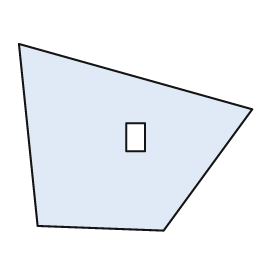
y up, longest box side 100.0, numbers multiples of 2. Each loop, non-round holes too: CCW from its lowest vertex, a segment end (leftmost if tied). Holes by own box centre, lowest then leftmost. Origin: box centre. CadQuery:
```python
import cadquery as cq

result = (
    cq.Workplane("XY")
    .moveTo(12.0, -40.0)
    .lineTo(50.0, 12.0)
    .lineTo(-50.0, 40.0)
    .lineTo(-42.0, -38.0)
    .close()
    .moveTo(-4.0, -6.0)
    .lineTo(4.0, -6.0)
    .lineTo(4.0, 6.0)
    .lineTo(-4.0, 6.0)
    .close()
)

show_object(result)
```